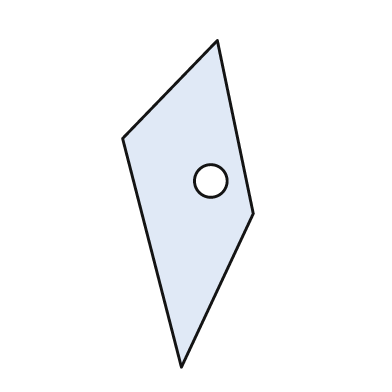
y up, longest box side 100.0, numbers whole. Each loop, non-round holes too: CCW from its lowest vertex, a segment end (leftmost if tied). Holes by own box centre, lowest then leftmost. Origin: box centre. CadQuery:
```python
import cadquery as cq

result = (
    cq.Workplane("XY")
    .moveTo(-2.0, -50.0)
    .lineTo(20.0, -3.0)
    .lineTo(9.0, 50.0)
    .lineTo(-20.0, 20.0)
    .close()
    .moveTo(7.0, 7.0)
    .circle(5.0)
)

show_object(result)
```